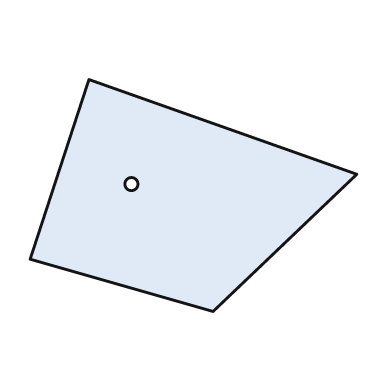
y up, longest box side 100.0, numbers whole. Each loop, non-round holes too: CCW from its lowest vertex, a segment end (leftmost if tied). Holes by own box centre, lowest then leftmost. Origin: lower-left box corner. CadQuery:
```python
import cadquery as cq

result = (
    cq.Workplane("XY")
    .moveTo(56.0, 0.0)
    .lineTo(100.0, 42.0)
    .lineTo(18.0, 71.0)
    .lineTo(0.0, 16.0)
    .close()
    .moveTo(31.0, 39.0)
    .circle(2.0)
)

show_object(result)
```